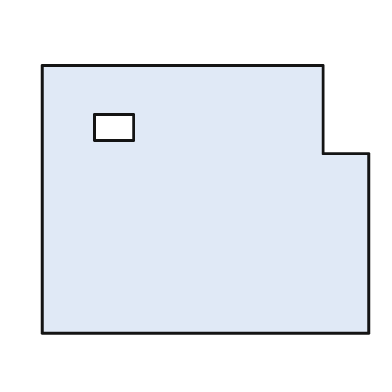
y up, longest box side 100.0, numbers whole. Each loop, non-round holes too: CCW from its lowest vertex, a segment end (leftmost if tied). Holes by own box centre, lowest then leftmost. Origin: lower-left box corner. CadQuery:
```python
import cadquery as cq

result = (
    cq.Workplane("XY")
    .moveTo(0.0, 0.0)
    .lineTo(100.0, 0.0)
    .lineTo(100.0, 55.0)
    .lineTo(86.0, 55.0)
    .lineTo(86.0, 82.0)
    .lineTo(0.0, 82.0)
    .close()
    .moveTo(16.0, 59.0)
    .lineTo(28.0, 59.0)
    .lineTo(28.0, 67.0)
    .lineTo(16.0, 67.0)
    .close()
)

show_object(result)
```